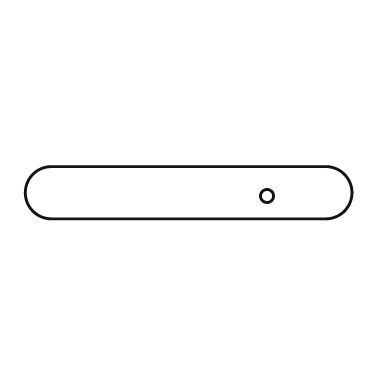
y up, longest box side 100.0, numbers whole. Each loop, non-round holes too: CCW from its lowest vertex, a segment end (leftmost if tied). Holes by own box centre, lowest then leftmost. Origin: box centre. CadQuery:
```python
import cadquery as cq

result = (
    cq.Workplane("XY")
    .moveTo(-42.0, -8.0)
    .lineTo(42.0, -8.0)
    .threePointArc((50.0, 0.0), (42.0, 8.0))
    .lineTo(-42.0, 8.0)
    .threePointArc((-50.0, 0.0), (-42.0, -8.0))
    .close()
    .moveTo(24.0, -1.0)
    .circle(2.0)
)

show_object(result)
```